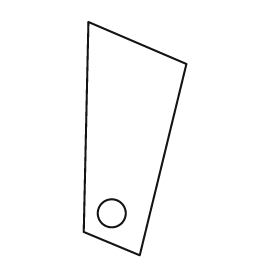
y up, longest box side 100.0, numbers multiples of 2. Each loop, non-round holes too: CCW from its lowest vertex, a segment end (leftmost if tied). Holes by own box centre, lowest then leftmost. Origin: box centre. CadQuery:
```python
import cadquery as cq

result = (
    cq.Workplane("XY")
    .moveTo(2.0, -50.0)
    .lineTo(22.0, 32.0)
    .lineTo(-20.0, 50.0)
    .lineTo(-22.0, -40.0)
    .close()
    .moveTo(-10.0, -32.0)
    .circle(6.0)
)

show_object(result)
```